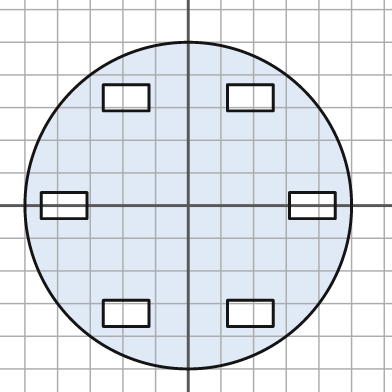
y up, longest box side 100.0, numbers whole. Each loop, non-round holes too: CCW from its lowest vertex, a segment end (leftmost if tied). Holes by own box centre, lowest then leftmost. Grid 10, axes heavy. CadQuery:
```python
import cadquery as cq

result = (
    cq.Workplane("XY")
    .moveTo(0.0, 0.0)
    .circle(50.0)
    .moveTo(-26.0, -37.0)
    .lineTo(-12.0, -37.0)
    .lineTo(-12.0, -29.0)
    .lineTo(-26.0, -29.0)
    .close()
    .moveTo(12.0, -37.0)
    .lineTo(26.0, -37.0)
    .lineTo(26.0, -29.0)
    .lineTo(12.0, -29.0)
    .close()
    .moveTo(-45.0, -4.0)
    .lineTo(-31.0, -4.0)
    .lineTo(-31.0, 4.0)
    .lineTo(-45.0, 4.0)
    .close()
    .moveTo(31.0, -4.0)
    .lineTo(45.0, -4.0)
    .lineTo(45.0, 4.0)
    .lineTo(31.0, 4.0)
    .close()
    .moveTo(-26.0, 29.0)
    .lineTo(-12.0, 29.0)
    .lineTo(-12.0, 37.0)
    .lineTo(-26.0, 37.0)
    .close()
    .moveTo(12.0, 29.0)
    .lineTo(26.0, 29.0)
    .lineTo(26.0, 37.0)
    .lineTo(12.0, 37.0)
    .close()
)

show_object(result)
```